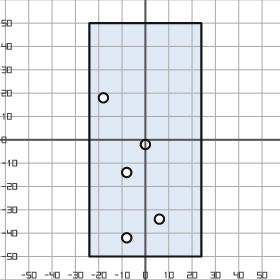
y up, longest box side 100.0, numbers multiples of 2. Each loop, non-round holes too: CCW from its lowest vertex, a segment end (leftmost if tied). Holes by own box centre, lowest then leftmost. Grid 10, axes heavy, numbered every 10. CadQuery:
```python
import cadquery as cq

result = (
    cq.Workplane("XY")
    .moveTo(-24.0, -50.0)
    .lineTo(24.0, -50.0)
    .lineTo(24.0, 50.0)
    .lineTo(-24.0, 50.0)
    .close()
    .moveTo(-8.0, -42.0)
    .circle(2.0)
    .moveTo(6.0, -34.0)
    .circle(2.0)
    .moveTo(-8.0, -14.0)
    .circle(2.0)
    .moveTo(0.0, -2.0)
    .circle(2.0)
    .moveTo(-18.0, 18.0)
    .circle(2.0)
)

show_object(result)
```